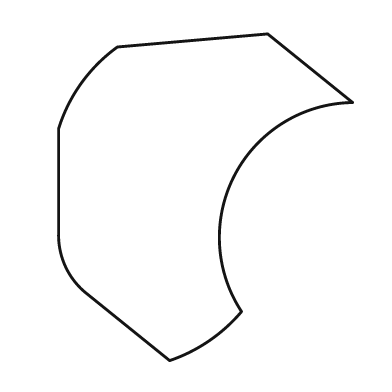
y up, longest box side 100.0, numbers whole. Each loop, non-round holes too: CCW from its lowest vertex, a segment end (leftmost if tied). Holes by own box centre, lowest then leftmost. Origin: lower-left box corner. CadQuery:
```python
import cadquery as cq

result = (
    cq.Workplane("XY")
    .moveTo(34.0, 0.0)
    .threePointArc((46.0, 6.0), (56.0, 15.0))
    .threePointArc((54.0, 57.0), (90.0, 79.0))
    .lineTo(64.0, 100.0)
    .lineTo(18.0, 96.0)
    .threePointArc((7.0, 85.0), (0.0, 71.0))
    .lineTo(0.0, 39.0)
    .threePointArc((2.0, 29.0), (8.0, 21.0))
    .close()
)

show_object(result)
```